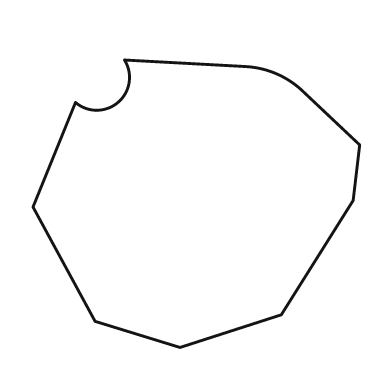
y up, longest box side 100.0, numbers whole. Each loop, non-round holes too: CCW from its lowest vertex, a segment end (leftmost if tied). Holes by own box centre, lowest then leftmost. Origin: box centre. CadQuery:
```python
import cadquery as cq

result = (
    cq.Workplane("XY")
    .moveTo(-5.0, -44.0)
    .lineTo(26.0, -34.0)
    .lineTo(48.0, 1.0)
    .lineTo(50.0, 18.0)
    .lineTo(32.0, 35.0)
    .threePointArc((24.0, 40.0), (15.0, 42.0))
    .lineTo(-22.0, 44.0)
    .threePointArc((-24.0, 31.0), (-37.0, 31.0))
    .lineTo(-50.0, -1.0)
    .lineTo(-31.0, -36.0)
    .close()
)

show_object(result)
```